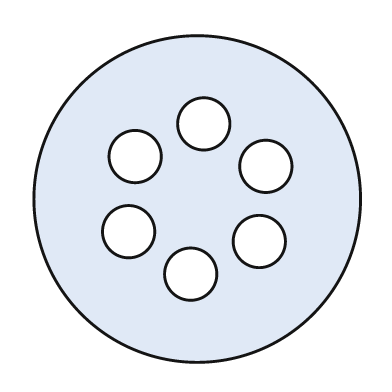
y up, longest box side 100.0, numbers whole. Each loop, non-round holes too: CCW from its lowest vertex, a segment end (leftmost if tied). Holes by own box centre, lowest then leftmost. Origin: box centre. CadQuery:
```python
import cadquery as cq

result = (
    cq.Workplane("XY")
    .moveTo(0.0, 0.0)
    .circle(50.0)
    .moveTo(-2.0, -23.0)
    .circle(8.0)
    .moveTo(19.0, -13.0)
    .circle(8.0)
    .moveTo(-21.0, -10.0)
    .circle(8.0)
    .moveTo(21.0, 10.0)
    .circle(8.0)
    .moveTo(-19.0, 13.0)
    .circle(8.0)
    .moveTo(2.0, 23.0)
    .circle(8.0)
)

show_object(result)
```